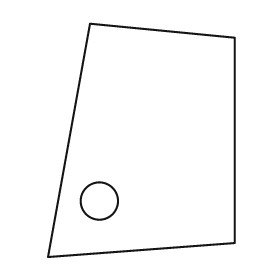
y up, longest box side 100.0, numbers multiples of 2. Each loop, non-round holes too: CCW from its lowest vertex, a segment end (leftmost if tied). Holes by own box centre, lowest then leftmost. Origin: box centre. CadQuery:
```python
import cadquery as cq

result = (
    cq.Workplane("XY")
    .moveTo(-40.0, -50.0)
    .lineTo(40.0, -44.0)
    .lineTo(40.0, 44.0)
    .lineTo(-22.0, 50.0)
    .close()
    .moveTo(-18.0, -26.0)
    .circle(8.0)
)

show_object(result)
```